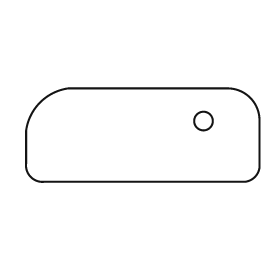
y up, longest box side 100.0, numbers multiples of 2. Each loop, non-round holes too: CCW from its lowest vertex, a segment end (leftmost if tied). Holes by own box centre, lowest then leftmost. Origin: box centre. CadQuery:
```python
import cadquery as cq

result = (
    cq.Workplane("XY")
    .moveTo(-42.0, -20.0)
    .lineTo(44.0, -20.0)
    .threePointArc((48.0, -18.0), (50.0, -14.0))
    .lineTo(50.0, 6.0)
    .threePointArc((46.0, 16.0), (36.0, 20.0))
    .lineTo(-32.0, 20.0)
    .threePointArc((-44.0, 14.0), (-50.0, 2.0))
    .lineTo(-50.0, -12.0)
    .threePointArc((-48.0, -18.0), (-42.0, -20.0))
    .close()
    .moveTo(26.0, 6.0)
    .circle(4.0)
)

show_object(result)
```